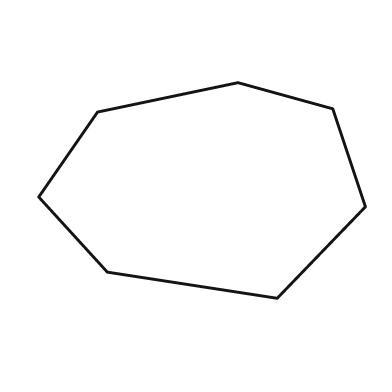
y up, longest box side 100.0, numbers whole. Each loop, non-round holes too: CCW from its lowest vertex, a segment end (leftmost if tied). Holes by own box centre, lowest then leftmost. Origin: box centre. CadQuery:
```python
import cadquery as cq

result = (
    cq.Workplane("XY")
    .moveTo(23.0, -33.0)
    .lineTo(50.0, -5.0)
    .lineTo(40.0, 25.0)
    .lineTo(11.0, 33.0)
    .lineTo(-32.0, 24.0)
    .lineTo(-50.0, -2.0)
    .lineTo(-29.0, -25.0)
    .close()
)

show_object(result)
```